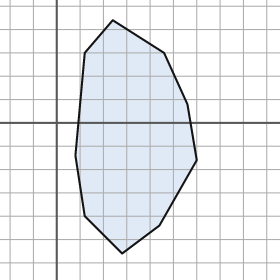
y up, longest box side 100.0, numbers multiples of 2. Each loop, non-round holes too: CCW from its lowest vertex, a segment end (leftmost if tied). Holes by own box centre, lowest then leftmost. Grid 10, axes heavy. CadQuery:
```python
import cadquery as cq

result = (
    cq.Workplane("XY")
    .moveTo(28.0, -56.0)
    .lineTo(44.0, -44.0)
    .lineTo(60.0, -16.0)
    .lineTo(56.0, 8.0)
    .lineTo(46.0, 30.0)
    .lineTo(24.0, 44.0)
    .lineTo(12.0, 30.0)
    .lineTo(8.0, -14.0)
    .lineTo(12.0, -40.0)
    .close()
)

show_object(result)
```